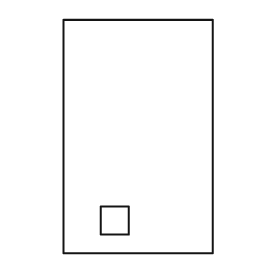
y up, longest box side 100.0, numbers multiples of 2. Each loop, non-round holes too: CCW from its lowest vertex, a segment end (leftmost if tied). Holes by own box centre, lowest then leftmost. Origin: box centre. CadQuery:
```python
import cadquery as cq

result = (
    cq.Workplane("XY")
    .moveTo(-32.0, -50.0)
    .lineTo(32.0, -50.0)
    .lineTo(32.0, 50.0)
    .lineTo(-32.0, 50.0)
    .close()
    .moveTo(-16.0, -42.0)
    .lineTo(-4.0, -42.0)
    .lineTo(-4.0, -30.0)
    .lineTo(-16.0, -30.0)
    .close()
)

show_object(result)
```